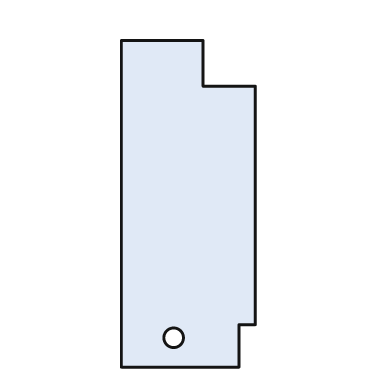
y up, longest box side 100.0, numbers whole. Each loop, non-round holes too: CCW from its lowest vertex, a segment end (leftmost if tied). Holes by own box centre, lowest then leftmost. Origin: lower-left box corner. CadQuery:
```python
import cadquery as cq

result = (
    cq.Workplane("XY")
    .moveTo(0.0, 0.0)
    .lineTo(36.0, 0.0)
    .lineTo(36.0, 13.0)
    .lineTo(41.0, 13.0)
    .lineTo(41.0, 86.0)
    .lineTo(25.0, 86.0)
    .lineTo(25.0, 100.0)
    .lineTo(0.0, 100.0)
    .close()
    .moveTo(16.0, 9.0)
    .circle(3.0)
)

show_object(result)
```